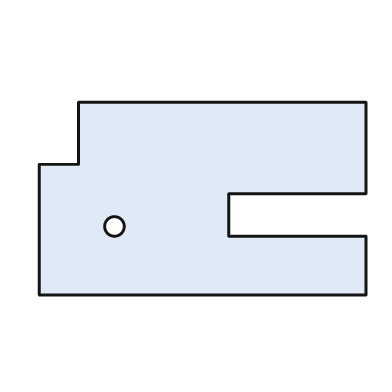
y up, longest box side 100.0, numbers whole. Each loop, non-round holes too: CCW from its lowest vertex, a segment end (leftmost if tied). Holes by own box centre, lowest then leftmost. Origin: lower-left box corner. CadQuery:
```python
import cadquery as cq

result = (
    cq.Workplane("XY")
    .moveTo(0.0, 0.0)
    .lineTo(100.0, 0.0)
    .lineTo(100.0, 18.0)
    .lineTo(58.0, 18.0)
    .lineTo(58.0, 31.0)
    .lineTo(100.0, 31.0)
    .lineTo(100.0, 59.0)
    .lineTo(12.0, 59.0)
    .lineTo(12.0, 40.0)
    .lineTo(0.0, 40.0)
    .close()
    .moveTo(23.0, 21.0)
    .circle(3.0)
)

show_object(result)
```